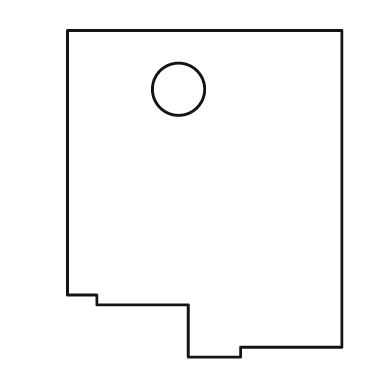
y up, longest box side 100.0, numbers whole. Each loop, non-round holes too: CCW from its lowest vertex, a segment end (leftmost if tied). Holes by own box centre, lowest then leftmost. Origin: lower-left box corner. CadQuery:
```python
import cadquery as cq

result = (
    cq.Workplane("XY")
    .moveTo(37.0, 0.0)
    .lineTo(53.0, 0.0)
    .lineTo(53.0, 3.0)
    .lineTo(84.0, 3.0)
    .lineTo(84.0, 100.0)
    .lineTo(0.0, 100.0)
    .lineTo(0.0, 19.0)
    .lineTo(9.0, 19.0)
    .lineTo(9.0, 16.0)
    .lineTo(37.0, 16.0)
    .close()
    .moveTo(34.0, 82.0)
    .circle(8.0)
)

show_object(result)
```